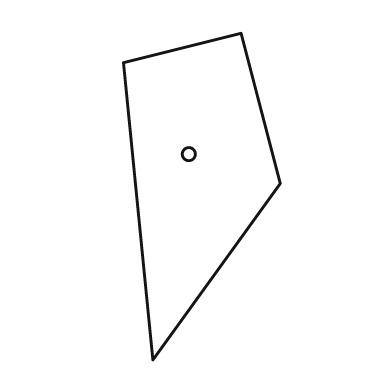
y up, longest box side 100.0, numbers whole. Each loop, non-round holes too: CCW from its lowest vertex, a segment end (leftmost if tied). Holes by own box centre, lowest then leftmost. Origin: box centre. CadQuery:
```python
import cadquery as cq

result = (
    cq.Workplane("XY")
    .moveTo(-15.0, -50.0)
    .lineTo(24.0, 4.0)
    .lineTo(12.0, 50.0)
    .lineTo(-24.0, 41.0)
    .close()
    .moveTo(-4.0, 13.0)
    .circle(2.0)
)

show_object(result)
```